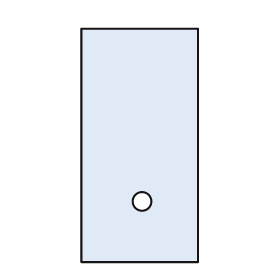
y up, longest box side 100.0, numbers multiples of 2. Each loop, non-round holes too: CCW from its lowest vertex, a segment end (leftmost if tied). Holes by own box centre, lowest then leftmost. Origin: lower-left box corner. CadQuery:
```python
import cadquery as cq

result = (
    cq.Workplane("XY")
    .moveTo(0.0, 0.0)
    .lineTo(50.0, 0.0)
    .lineTo(50.0, 100.0)
    .lineTo(0.0, 100.0)
    .close()
    .moveTo(26.0, 26.0)
    .circle(4.0)
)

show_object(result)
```